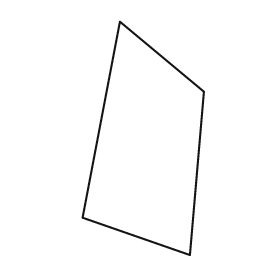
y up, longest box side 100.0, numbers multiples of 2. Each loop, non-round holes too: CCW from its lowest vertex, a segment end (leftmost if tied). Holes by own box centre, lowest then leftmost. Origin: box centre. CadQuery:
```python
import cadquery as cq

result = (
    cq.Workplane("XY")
    .moveTo(20.0, -50.0)
    .lineTo(26.0, 20.0)
    .lineTo(-10.0, 50.0)
    .lineTo(-26.0, -34.0)
    .close()
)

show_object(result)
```